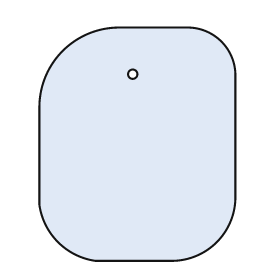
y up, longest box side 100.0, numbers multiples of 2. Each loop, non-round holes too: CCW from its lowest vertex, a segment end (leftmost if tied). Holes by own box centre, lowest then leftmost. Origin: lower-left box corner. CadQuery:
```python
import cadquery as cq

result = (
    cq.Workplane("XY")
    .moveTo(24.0, 0.0)
    .lineTo(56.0, 0.0)
    .threePointArc((76.0, 8.0), (84.0, 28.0))
    .lineTo(84.0, 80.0)
    .threePointArc((78.0, 94.0), (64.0, 100.0))
    .lineTo(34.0, 100.0)
    .threePointArc((10.0, 90.0), (0.0, 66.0))
    .lineTo(0.0, 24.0)
    .threePointArc((8.0, 8.0), (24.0, 0.0))
    .close()
    .moveTo(40.0, 80.0)
    .circle(2.0)
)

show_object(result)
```